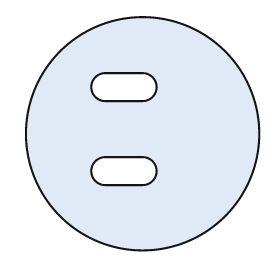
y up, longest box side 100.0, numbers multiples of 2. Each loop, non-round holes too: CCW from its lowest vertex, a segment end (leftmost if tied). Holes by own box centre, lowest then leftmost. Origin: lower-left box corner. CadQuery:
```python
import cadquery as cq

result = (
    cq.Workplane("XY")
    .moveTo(50.0, 50.0)
    .circle(50.0)
    .moveTo(34.0, 28.0)
    .lineTo(50.0, 28.0)
    .threePointArc((56.0, 34.0), (50.0, 40.0))
    .lineTo(34.0, 40.0)
    .threePointArc((28.0, 34.0), (34.0, 28.0))
    .close()
    .moveTo(34.0, 64.0)
    .lineTo(50.0, 64.0)
    .threePointArc((56.0, 70.0), (50.0, 76.0))
    .lineTo(34.0, 76.0)
    .threePointArc((28.0, 70.0), (34.0, 64.0))
    .close()
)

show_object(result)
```